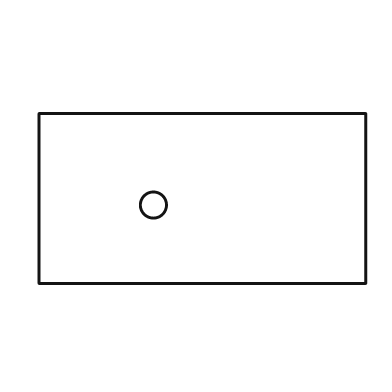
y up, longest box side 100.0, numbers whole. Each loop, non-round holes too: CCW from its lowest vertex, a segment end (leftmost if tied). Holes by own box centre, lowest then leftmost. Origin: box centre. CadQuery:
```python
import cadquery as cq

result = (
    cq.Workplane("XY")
    .moveTo(-50.0, -26.0)
    .lineTo(50.0, -26.0)
    .lineTo(50.0, 26.0)
    .lineTo(-50.0, 26.0)
    .close()
    .moveTo(-15.0, -2.0)
    .circle(4.0)
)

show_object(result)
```